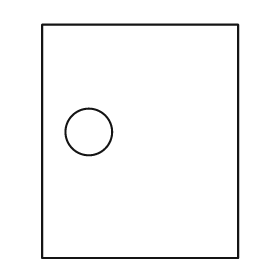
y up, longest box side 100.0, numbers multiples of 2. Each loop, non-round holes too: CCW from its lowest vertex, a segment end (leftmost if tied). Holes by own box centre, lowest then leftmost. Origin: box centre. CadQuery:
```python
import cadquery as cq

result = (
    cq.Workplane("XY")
    .moveTo(-42.0, -50.0)
    .lineTo(42.0, -50.0)
    .lineTo(42.0, 50.0)
    .lineTo(-42.0, 50.0)
    .close()
    .moveTo(-22.0, 4.0)
    .circle(10.0)
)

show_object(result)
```